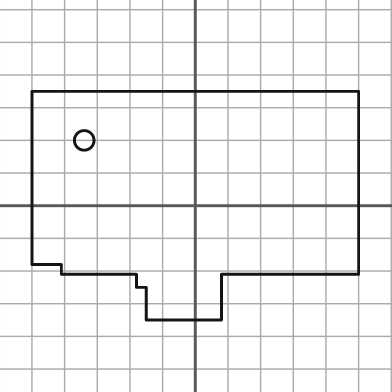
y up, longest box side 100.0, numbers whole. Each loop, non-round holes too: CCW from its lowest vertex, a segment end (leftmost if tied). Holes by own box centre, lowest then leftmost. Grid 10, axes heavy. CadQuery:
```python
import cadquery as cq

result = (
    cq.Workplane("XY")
    .moveTo(-15.0, -35.0)
    .lineTo(8.0, -35.0)
    .lineTo(8.0, -21.0)
    .lineTo(50.0, -21.0)
    .lineTo(50.0, 35.0)
    .lineTo(-50.0, 35.0)
    .lineTo(-50.0, -18.0)
    .lineTo(-41.0, -18.0)
    .lineTo(-41.0, -21.0)
    .lineTo(-18.0, -21.0)
    .lineTo(-18.0, -25.0)
    .lineTo(-15.0, -25.0)
    .close()
    .moveTo(-34.0, 20.0)
    .circle(3.0)
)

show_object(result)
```